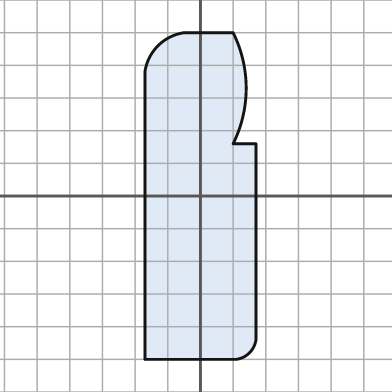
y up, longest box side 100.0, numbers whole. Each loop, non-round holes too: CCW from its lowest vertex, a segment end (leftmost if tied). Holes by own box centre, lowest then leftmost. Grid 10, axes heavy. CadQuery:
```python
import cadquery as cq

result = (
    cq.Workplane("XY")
    .moveTo(-17.0, -50.0)
    .lineTo(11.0, -50.0)
    .threePointArc((15.0, -48.0), (17.0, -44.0))
    .lineTo(17.0, 16.0)
    .lineTo(10.0, 16.0)
    .threePointArc((14.0, 33.0), (10.0, 50.0))
    .lineTo(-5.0, 50.0)
    .threePointArc((-13.0, 46.0), (-17.0, 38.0))
    .close()
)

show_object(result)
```